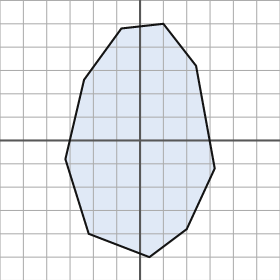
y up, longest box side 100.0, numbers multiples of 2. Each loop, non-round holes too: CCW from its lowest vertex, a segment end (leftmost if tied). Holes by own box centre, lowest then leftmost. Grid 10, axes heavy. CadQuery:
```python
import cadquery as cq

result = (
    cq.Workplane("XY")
    .moveTo(4.0, -50.0)
    .lineTo(20.0, -38.0)
    .lineTo(32.0, -12.0)
    .lineTo(24.0, 32.0)
    .lineTo(10.0, 50.0)
    .lineTo(-8.0, 48.0)
    .lineTo(-24.0, 26.0)
    .lineTo(-32.0, -8.0)
    .lineTo(-22.0, -40.0)
    .close()
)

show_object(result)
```